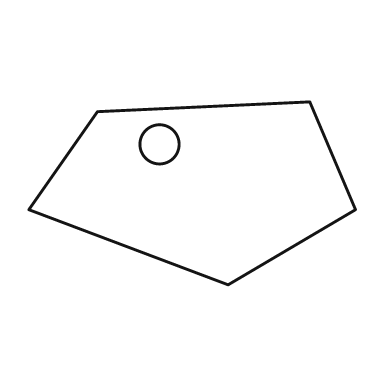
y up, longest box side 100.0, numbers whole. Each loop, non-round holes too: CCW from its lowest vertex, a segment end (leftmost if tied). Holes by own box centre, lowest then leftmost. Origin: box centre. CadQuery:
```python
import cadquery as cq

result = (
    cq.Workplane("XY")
    .moveTo(11.0, -28.0)
    .lineTo(50.0, -5.0)
    .lineTo(36.0, 28.0)
    .lineTo(-29.0, 25.0)
    .lineTo(-50.0, -5.0)
    .close()
    .moveTo(-10.0, 15.0)
    .circle(6.0)
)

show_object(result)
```